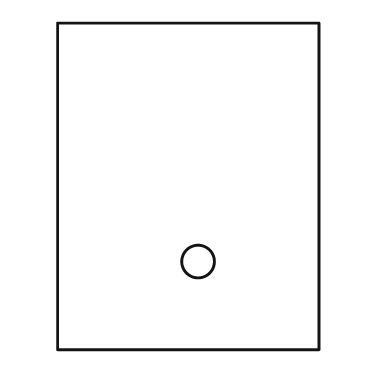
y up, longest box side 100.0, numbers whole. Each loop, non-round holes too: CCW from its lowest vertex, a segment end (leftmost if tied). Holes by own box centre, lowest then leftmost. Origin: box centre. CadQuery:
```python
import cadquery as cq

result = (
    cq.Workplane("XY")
    .moveTo(-40.0, -50.0)
    .lineTo(40.0, -50.0)
    .lineTo(40.0, 50.0)
    .lineTo(-40.0, 50.0)
    .close()
    .moveTo(3.0, -23.0)
    .circle(5.0)
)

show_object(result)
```